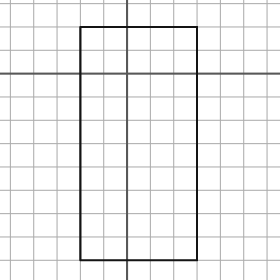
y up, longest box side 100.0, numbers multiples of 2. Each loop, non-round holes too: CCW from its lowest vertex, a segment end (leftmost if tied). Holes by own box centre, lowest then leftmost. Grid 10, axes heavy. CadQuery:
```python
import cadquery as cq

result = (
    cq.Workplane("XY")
    .moveTo(-20.0, -80.0)
    .lineTo(30.0, -80.0)
    .lineTo(30.0, 20.0)
    .lineTo(-20.0, 20.0)
    .close()
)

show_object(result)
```